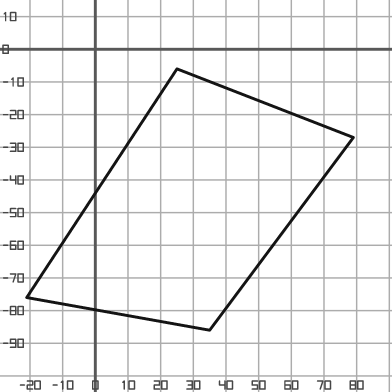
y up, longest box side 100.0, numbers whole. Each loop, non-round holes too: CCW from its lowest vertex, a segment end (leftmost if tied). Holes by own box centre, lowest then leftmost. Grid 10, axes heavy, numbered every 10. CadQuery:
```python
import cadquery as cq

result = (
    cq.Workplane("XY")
    .moveTo(35.0, -86.0)
    .lineTo(79.0, -27.0)
    .lineTo(25.0, -6.0)
    .lineTo(-21.0, -76.0)
    .close()
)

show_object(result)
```